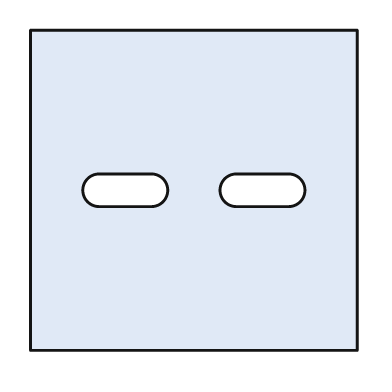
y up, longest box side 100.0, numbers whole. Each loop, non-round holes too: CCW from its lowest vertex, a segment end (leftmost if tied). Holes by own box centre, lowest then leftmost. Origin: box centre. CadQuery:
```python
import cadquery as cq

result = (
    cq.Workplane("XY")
    .moveTo(-50.0, -49.0)
    .lineTo(50.0, -49.0)
    .lineTo(50.0, 49.0)
    .lineTo(-50.0, 49.0)
    .close()
    .moveTo(-29.0, -5.0)
    .lineTo(-13.0, -5.0)
    .threePointArc((-8.0, 0.0), (-13.0, 5.0))
    .lineTo(-29.0, 5.0)
    .threePointArc((-34.0, 0.0), (-29.0, -5.0))
    .close()
    .moveTo(13.0, -5.0)
    .lineTo(29.0, -5.0)
    .threePointArc((34.0, 0.0), (29.0, 5.0))
    .lineTo(13.0, 5.0)
    .threePointArc((8.0, 0.0), (13.0, -5.0))
    .close()
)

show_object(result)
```